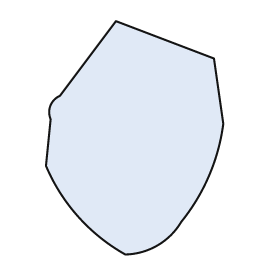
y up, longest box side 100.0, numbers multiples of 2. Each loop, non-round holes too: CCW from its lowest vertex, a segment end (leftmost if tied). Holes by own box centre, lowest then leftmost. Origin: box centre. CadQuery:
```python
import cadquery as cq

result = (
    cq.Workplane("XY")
    .moveTo(-4.0, -50.0)
    .threePointArc((10.0, -46.0), (20.0, -36.0))
    .threePointArc((32.0, -16.0), (38.0, 6.0))
    .lineTo(34.0, 34.0)
    .lineTo(-8.0, 50.0)
    .lineTo(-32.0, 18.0)
    .threePointArc((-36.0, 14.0), (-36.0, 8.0))
    .lineTo(-38.0, -12.0)
    .threePointArc((-24.0, -34.0), (-4.0, -50.0))
    .close()
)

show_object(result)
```